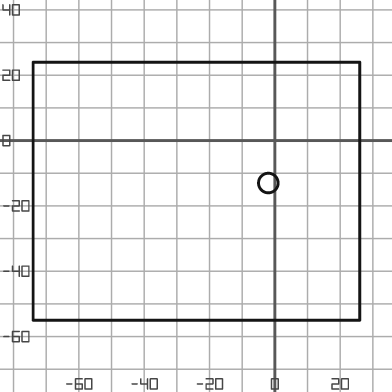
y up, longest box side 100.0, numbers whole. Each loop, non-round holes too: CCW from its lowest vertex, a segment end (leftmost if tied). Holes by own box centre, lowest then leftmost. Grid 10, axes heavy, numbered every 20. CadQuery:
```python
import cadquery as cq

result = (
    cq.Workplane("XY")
    .moveTo(-74.0, -55.0)
    .lineTo(26.0, -55.0)
    .lineTo(26.0, 24.0)
    .lineTo(-74.0, 24.0)
    .close()
    .moveTo(-2.0, -13.0)
    .circle(3.0)
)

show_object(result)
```